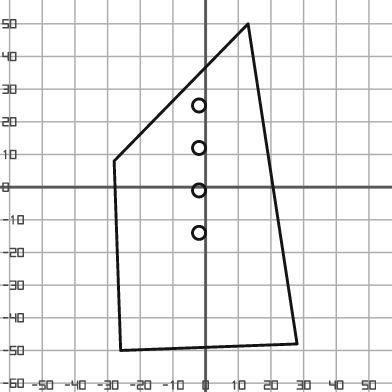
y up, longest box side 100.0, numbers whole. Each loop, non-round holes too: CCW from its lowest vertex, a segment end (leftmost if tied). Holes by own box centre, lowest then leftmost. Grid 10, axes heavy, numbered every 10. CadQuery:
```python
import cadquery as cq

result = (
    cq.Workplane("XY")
    .moveTo(-26.0, -50.0)
    .lineTo(28.0, -48.0)
    .lineTo(13.0, 50.0)
    .lineTo(-28.0, 8.0)
    .close()
    .moveTo(-2.0, -14.0)
    .circle(2.0)
    .moveTo(-2.0, -1.0)
    .circle(2.0)
    .moveTo(-2.0, 12.0)
    .circle(2.0)
    .moveTo(-2.0, 25.0)
    .circle(2.0)
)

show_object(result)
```